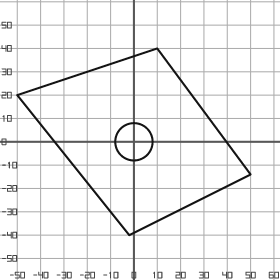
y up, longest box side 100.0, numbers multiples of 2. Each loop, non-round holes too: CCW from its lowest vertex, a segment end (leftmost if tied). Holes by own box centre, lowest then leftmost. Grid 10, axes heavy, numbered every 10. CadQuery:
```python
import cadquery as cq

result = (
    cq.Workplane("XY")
    .moveTo(-2.0, -40.0)
    .lineTo(50.0, -14.0)
    .lineTo(10.0, 40.0)
    .lineTo(-50.0, 20.0)
    .close()
    .moveTo(0.0, 0.0)
    .circle(8.0)
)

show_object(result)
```